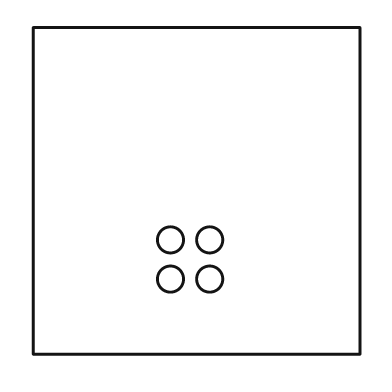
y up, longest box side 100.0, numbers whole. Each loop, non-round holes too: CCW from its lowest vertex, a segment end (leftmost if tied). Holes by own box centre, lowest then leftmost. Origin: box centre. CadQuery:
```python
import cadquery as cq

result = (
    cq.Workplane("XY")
    .moveTo(-50.0, -50.0)
    .lineTo(50.0, -50.0)
    .lineTo(50.0, 50.0)
    .lineTo(-50.0, 50.0)
    .close()
    .moveTo(-8.0, -27.0)
    .circle(4.0)
    .moveTo(4.0, -27.0)
    .circle(4.0)
    .moveTo(-8.0, -15.0)
    .circle(4.0)
    .moveTo(4.0, -15.0)
    .circle(4.0)
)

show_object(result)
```